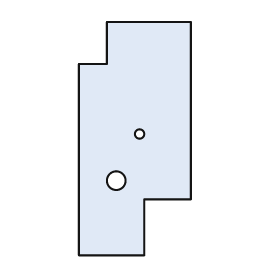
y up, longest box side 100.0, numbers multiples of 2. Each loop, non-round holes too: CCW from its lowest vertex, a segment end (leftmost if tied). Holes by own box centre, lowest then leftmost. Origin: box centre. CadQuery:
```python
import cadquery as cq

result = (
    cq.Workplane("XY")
    .moveTo(-24.0, -50.0)
    .lineTo(4.0, -50.0)
    .lineTo(4.0, -26.0)
    .lineTo(24.0, -26.0)
    .lineTo(24.0, 50.0)
    .lineTo(-12.0, 50.0)
    .lineTo(-12.0, 32.0)
    .lineTo(-24.0, 32.0)
    .close()
    .moveTo(-8.0, -18.0)
    .circle(4.0)
    .moveTo(2.0, 2.0)
    .circle(2.0)
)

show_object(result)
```